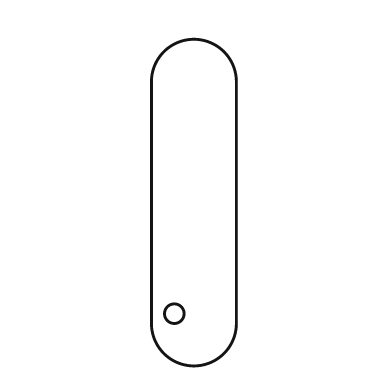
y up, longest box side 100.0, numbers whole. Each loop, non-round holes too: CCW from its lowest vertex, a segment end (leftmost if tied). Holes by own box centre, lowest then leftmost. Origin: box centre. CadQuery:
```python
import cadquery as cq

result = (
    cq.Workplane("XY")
    .moveTo(-13.0, -37.0)
    .threePointArc((0.0, -50.0), (13.0, -37.0))
    .lineTo(13.0, 37.0)
    .threePointArc((0.0, 50.0), (-13.0, 37.0))
    .close()
    .moveTo(-6.0, -34.0)
    .circle(3.0)
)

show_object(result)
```